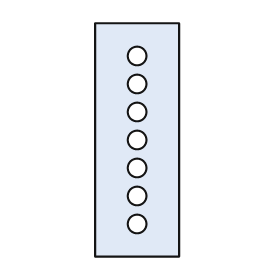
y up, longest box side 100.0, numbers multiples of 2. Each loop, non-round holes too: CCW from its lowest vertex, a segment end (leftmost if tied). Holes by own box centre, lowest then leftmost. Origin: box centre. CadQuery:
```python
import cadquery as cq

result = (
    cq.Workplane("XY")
    .moveTo(-18.0, -50.0)
    .lineTo(18.0, -50.0)
    .lineTo(18.0, 50.0)
    .lineTo(-18.0, 50.0)
    .close()
    .moveTo(0.0, -36.0)
    .circle(4.0)
    .moveTo(0.0, -24.0)
    .circle(4.0)
    .moveTo(0.0, -12.0)
    .circle(4.0)
    .moveTo(0.0, 0.0)
    .circle(4.0)
    .moveTo(0.0, 12.0)
    .circle(4.0)
    .moveTo(0.0, 24.0)
    .circle(4.0)
    .moveTo(0.0, 36.0)
    .circle(4.0)
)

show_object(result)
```